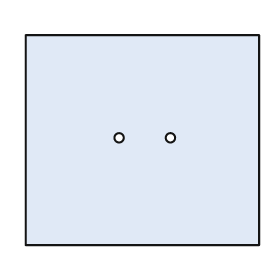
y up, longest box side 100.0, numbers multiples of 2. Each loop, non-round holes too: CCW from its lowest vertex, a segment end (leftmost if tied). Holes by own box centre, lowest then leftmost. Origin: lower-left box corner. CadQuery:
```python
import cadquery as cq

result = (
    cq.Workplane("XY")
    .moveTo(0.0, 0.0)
    .lineTo(100.0, 0.0)
    .lineTo(100.0, 90.0)
    .lineTo(0.0, 90.0)
    .close()
    .moveTo(40.0, 46.0)
    .circle(2.0)
    .moveTo(62.0, 46.0)
    .circle(2.0)
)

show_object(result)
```